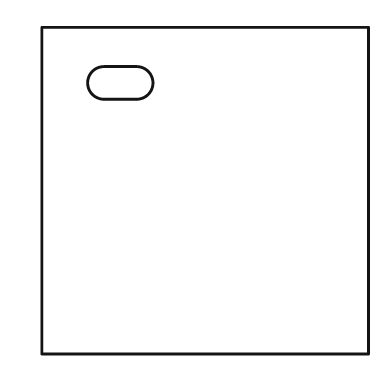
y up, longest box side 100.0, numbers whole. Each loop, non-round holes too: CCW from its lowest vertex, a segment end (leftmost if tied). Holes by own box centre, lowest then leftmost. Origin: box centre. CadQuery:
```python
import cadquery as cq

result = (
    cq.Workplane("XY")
    .moveTo(-50.0, -50.0)
    .lineTo(50.0, -50.0)
    .lineTo(50.0, 50.0)
    .lineTo(-50.0, 50.0)
    .close()
    .moveTo(-31.0, 28.0)
    .lineTo(-21.0, 28.0)
    .threePointArc((-16.0, 33.0), (-21.0, 38.0))
    .lineTo(-31.0, 38.0)
    .threePointArc((-36.0, 33.0), (-31.0, 28.0))
    .close()
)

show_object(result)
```